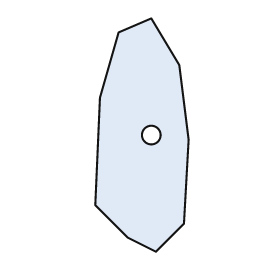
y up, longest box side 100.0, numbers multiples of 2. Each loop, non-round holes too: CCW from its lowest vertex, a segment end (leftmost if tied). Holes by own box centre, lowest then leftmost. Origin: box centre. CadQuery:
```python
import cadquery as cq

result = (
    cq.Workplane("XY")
    .moveTo(6.0, -50.0)
    .lineTo(18.0, -38.0)
    .lineTo(20.0, -2.0)
    .lineTo(16.0, 30.0)
    .lineTo(4.0, 50.0)
    .lineTo(-10.0, 44.0)
    .lineTo(-18.0, 16.0)
    .lineTo(-20.0, -30.0)
    .lineTo(-6.0, -44.0)
    .close()
    .moveTo(4.0, 0.0)
    .circle(4.0)
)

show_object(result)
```